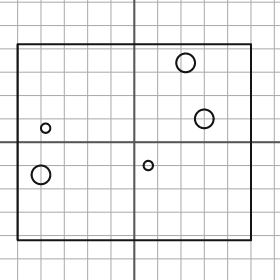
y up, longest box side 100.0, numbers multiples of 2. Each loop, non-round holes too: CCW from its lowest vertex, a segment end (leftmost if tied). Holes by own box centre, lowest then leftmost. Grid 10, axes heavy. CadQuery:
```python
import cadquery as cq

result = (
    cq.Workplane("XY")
    .moveTo(-50.0, -42.0)
    .lineTo(50.0, -42.0)
    .lineTo(50.0, 42.0)
    .lineTo(-50.0, 42.0)
    .close()
    .moveTo(-40.0, -14.0)
    .circle(4.0)
    .moveTo(6.0, -10.0)
    .circle(2.0)
    .moveTo(-38.0, 6.0)
    .circle(2.0)
    .moveTo(30.0, 10.0)
    .circle(4.0)
    .moveTo(22.0, 34.0)
    .circle(4.0)
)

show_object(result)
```